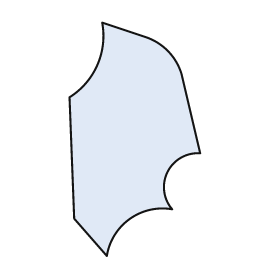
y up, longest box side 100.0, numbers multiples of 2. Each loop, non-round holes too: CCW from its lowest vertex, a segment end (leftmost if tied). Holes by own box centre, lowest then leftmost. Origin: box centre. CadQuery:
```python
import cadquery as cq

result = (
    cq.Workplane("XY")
    .moveTo(-12.0, -50.0)
    .threePointArc((-2.0, -34.0), (16.0, -30.0))
    .threePointArc((14.0, -14.0), (28.0, -6.0))
    .lineTo(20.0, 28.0)
    .threePointArc((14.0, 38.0), (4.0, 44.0))
    .lineTo(-14.0, 50.0)
    .threePointArc((-16.0, 32.0), (-28.0, 18.0))
    .lineTo(-26.0, -34.0)
    .close()
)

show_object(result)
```